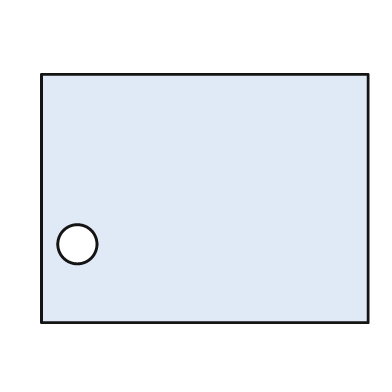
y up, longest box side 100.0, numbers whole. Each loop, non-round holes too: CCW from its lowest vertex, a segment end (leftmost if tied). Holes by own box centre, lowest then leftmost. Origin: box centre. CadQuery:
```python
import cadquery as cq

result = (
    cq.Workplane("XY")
    .moveTo(-50.0, -38.0)
    .lineTo(50.0, -38.0)
    .lineTo(50.0, 38.0)
    .lineTo(-50.0, 38.0)
    .close()
    .moveTo(-39.0, -14.0)
    .circle(6.0)
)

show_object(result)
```